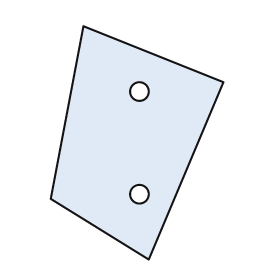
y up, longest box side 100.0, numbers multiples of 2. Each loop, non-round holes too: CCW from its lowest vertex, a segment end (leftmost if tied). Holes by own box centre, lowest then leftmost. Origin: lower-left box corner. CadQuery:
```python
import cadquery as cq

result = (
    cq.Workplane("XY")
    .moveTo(42.0, 0.0)
    .lineTo(74.0, 76.0)
    .lineTo(14.0, 100.0)
    .lineTo(0.0, 26.0)
    .close()
    .moveTo(38.0, 28.0)
    .circle(4.0)
    .moveTo(38.0, 72.0)
    .circle(4.0)
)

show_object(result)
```